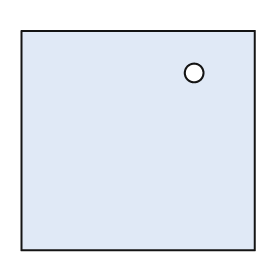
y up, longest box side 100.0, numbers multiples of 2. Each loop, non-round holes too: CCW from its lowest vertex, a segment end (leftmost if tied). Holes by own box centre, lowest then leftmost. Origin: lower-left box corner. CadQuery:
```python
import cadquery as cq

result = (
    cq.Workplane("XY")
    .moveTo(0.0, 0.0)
    .lineTo(100.0, 0.0)
    .lineTo(100.0, 94.0)
    .lineTo(0.0, 94.0)
    .close()
    .moveTo(74.0, 76.0)
    .circle(4.0)
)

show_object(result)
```